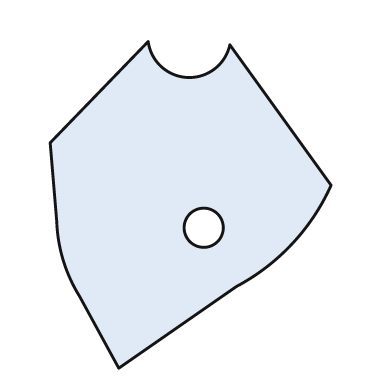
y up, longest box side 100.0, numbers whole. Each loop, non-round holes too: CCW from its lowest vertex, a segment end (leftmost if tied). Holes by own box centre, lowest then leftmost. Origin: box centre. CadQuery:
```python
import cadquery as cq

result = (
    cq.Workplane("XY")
    .moveTo(-22.0, -50.0)
    .lineTo(14.0, -25.0)
    .threePointArc((31.0, -12.0), (43.0, 6.0))
    .lineTo(12.0, 49.0)
    .threePointArc((-1.0, 39.0), (-13.0, 50.0))
    .lineTo(-43.0, 19.0)
    .lineTo(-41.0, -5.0)
    .threePointArc((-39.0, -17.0), (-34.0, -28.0))
    .close()
    .moveTo(4.0, -7.0)
    .circle(6.0)
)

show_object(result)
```